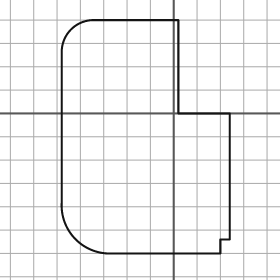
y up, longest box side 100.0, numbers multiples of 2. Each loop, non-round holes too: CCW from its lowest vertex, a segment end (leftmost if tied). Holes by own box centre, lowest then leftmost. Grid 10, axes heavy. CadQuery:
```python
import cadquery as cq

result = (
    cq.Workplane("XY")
    .moveTo(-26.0, -60.0)
    .lineTo(20.0, -60.0)
    .lineTo(20.0, -54.0)
    .lineTo(24.0, -54.0)
    .lineTo(24.0, 0.0)
    .lineTo(2.0, 0.0)
    .lineTo(2.0, 40.0)
    .lineTo(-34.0, 40.0)
    .threePointArc((-44.0, 36.0), (-48.0, 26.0))
    .lineTo(-48.0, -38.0)
    .threePointArc((-42.0, -54.0), (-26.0, -60.0))
    .close()
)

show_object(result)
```